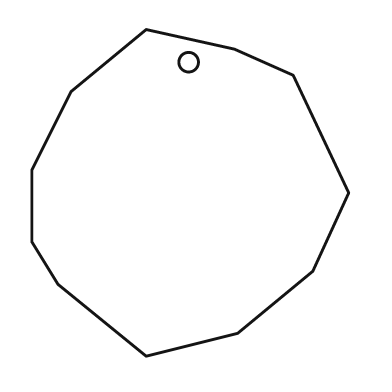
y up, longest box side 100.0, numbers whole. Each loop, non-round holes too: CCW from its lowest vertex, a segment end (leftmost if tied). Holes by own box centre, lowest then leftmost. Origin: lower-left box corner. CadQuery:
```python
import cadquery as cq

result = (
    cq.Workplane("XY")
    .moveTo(35.0, 0.0)
    .lineTo(63.0, 7.0)
    .lineTo(86.0, 26.0)
    .lineTo(97.0, 50.0)
    .lineTo(80.0, 86.0)
    .lineTo(62.0, 94.0)
    .lineTo(35.0, 100.0)
    .lineTo(12.0, 81.0)
    .lineTo(0.0, 57.0)
    .lineTo(0.0, 35.0)
    .lineTo(8.0, 22.0)
    .close()
    .moveTo(48.0, 90.0)
    .circle(3.0)
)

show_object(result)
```